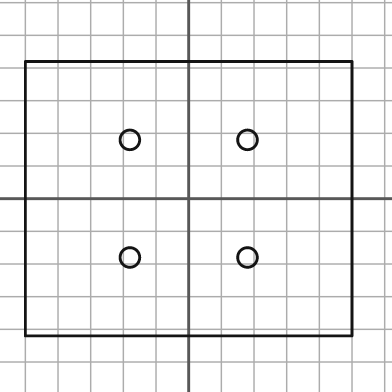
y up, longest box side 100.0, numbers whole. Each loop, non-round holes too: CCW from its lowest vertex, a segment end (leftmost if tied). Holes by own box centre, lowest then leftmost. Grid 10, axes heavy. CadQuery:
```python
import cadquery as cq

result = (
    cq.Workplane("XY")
    .moveTo(-50.0, -42.0)
    .lineTo(50.0, -42.0)
    .lineTo(50.0, 42.0)
    .lineTo(-50.0, 42.0)
    .close()
    .moveTo(-18.0, -18.0)
    .circle(3.0)
    .moveTo(18.0, -18.0)
    .circle(3.0)
    .moveTo(-18.0, 18.0)
    .circle(3.0)
    .moveTo(18.0, 18.0)
    .circle(3.0)
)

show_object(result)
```